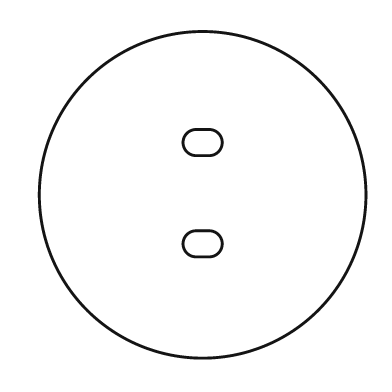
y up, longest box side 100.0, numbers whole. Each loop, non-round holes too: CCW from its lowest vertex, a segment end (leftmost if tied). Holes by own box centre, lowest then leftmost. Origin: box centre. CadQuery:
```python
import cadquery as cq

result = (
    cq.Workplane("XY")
    .moveTo(0.0, 0.0)
    .circle(50.0)
    .moveTo(-2.0, -19.0)
    .lineTo(2.0, -19.0)
    .threePointArc((6.0, -15.0), (2.0, -11.0))
    .lineTo(-2.0, -11.0)
    .threePointArc((-6.0, -15.0), (-2.0, -19.0))
    .close()
    .moveTo(-2.0, 12.0)
    .lineTo(2.0, 12.0)
    .threePointArc((6.0, 16.0), (2.0, 20.0))
    .lineTo(-2.0, 20.0)
    .threePointArc((-6.0, 16.0), (-2.0, 12.0))
    .close()
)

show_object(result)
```